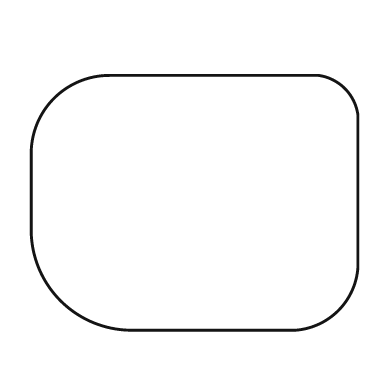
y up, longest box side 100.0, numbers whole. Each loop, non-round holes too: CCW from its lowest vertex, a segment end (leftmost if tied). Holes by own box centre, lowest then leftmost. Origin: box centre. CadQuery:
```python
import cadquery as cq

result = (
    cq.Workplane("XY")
    .moveTo(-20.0, -39.0)
    .lineTo(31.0, -39.0)
    .threePointArc((44.0, -33.0), (50.0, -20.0))
    .lineTo(50.0, 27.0)
    .threePointArc((46.0, 35.0), (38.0, 39.0))
    .lineTo(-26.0, 39.0)
    .threePointArc((-43.0, 32.0), (-50.0, 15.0))
    .lineTo(-50.0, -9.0)
    .threePointArc((-41.0, -30.0), (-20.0, -39.0))
    .close()
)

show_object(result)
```